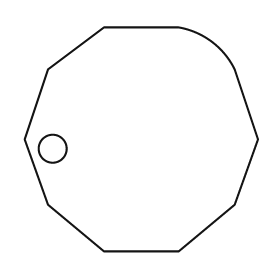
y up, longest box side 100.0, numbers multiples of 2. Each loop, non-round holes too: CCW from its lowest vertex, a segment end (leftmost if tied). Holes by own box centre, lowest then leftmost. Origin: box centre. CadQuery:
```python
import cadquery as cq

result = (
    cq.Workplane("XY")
    .moveTo(-16.0, -48.0)
    .lineTo(16.0, -48.0)
    .lineTo(40.0, -28.0)
    .lineTo(50.0, 0.0)
    .lineTo(40.0, 30.0)
    .threePointArc((30.0, 42.0), (16.0, 48.0))
    .lineTo(-16.0, 48.0)
    .lineTo(-40.0, 30.0)
    .lineTo(-50.0, 0.0)
    .lineTo(-40.0, -28.0)
    .close()
    .moveTo(-38.0, -4.0)
    .circle(6.0)
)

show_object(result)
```